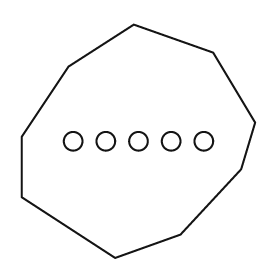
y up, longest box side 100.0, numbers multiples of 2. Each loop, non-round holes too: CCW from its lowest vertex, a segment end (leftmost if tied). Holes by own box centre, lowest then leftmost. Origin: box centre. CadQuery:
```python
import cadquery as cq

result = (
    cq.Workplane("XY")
    .moveTo(-10.0, -50.0)
    .lineTo(18.0, -40.0)
    .lineTo(44.0, -12.0)
    .lineTo(50.0, 8.0)
    .lineTo(32.0, 38.0)
    .lineTo(-2.0, 50.0)
    .lineTo(-30.0, 32.0)
    .lineTo(-50.0, 2.0)
    .lineTo(-50.0, -24.0)
    .close()
    .moveTo(-28.0, 0.0)
    .circle(4.0)
    .moveTo(-14.0, 0.0)
    .circle(4.0)
    .moveTo(0.0, 0.0)
    .circle(4.0)
    .moveTo(14.0, 0.0)
    .circle(4.0)
    .moveTo(28.0, 0.0)
    .circle(4.0)
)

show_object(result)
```